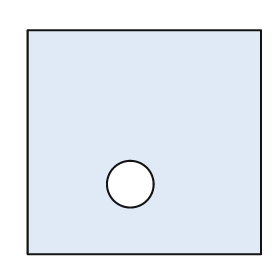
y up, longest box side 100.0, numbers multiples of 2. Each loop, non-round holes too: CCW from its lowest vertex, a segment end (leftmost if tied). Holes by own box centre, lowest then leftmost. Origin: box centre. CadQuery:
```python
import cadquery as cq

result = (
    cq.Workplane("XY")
    .moveTo(-50.0, -48.0)
    .lineTo(50.0, -48.0)
    .lineTo(50.0, 48.0)
    .lineTo(-50.0, 48.0)
    .close()
    .moveTo(-6.0, -18.0)
    .circle(10.0)
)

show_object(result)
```